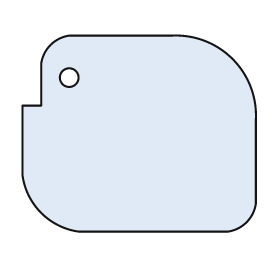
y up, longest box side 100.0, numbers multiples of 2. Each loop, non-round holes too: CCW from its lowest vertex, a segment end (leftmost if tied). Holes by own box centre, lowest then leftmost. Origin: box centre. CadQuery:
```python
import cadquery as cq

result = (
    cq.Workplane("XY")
    .moveTo(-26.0, -42.0)
    .lineTo(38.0, -42.0)
    .threePointArc((46.0, -38.0), (50.0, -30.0))
    .lineTo(50.0, 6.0)
    .threePointArc((40.0, 32.0), (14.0, 42.0))
    .lineTo(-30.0, 42.0)
    .threePointArc((-38.0, 38.0), (-42.0, 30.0))
    .lineTo(-42.0, 12.0)
    .lineTo(-50.0, 12.0)
    .lineTo(-50.0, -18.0)
    .threePointArc((-42.0, -34.0), (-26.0, -42.0))
    .close()
    .moveTo(-30.0, 24.0)
    .circle(4.0)
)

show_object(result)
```